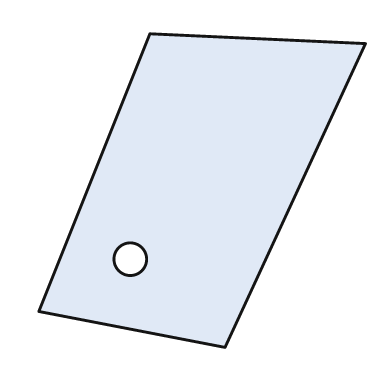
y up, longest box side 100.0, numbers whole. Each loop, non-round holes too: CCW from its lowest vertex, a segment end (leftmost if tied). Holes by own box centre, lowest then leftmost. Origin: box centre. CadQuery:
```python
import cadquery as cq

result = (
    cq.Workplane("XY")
    .moveTo(7.0, -48.0)
    .lineTo(50.0, 45.0)
    .lineTo(-16.0, 48.0)
    .lineTo(-50.0, -37.0)
    .close()
    .moveTo(-22.0, -21.0)
    .circle(5.0)
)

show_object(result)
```